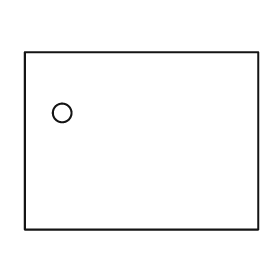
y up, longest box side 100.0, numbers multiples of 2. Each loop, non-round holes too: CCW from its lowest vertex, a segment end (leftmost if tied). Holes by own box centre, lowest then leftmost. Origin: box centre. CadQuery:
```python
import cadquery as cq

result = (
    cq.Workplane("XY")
    .moveTo(-50.0, -38.0)
    .lineTo(50.0, -38.0)
    .lineTo(50.0, 38.0)
    .lineTo(-50.0, 38.0)
    .close()
    .moveTo(-34.0, 12.0)
    .circle(4.0)
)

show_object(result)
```